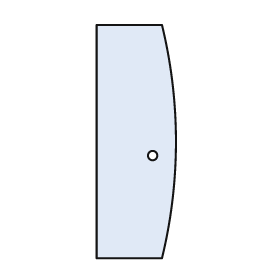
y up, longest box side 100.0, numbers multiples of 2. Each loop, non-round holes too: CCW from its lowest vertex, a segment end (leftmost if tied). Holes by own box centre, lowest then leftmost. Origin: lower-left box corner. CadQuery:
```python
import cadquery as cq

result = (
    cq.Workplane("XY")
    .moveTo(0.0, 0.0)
    .lineTo(28.0, 0.0)
    .threePointArc((34.0, 50.0), (28.0, 100.0))
    .lineTo(0.0, 100.0)
    .close()
    .moveTo(24.0, 44.0)
    .circle(2.0)
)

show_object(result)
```